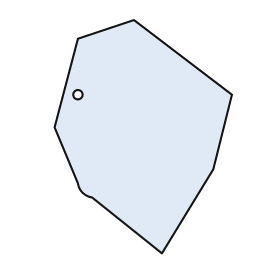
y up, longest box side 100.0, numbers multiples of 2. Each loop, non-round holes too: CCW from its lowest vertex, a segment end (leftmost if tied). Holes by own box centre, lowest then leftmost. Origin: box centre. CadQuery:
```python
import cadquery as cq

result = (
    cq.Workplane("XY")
    .moveTo(8.0, -50.0)
    .lineTo(30.0, -14.0)
    .lineTo(38.0, 18.0)
    .lineTo(-4.0, 50.0)
    .lineTo(-28.0, 42.0)
    .lineTo(-38.0, 4.0)
    .lineTo(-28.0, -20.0)
    .threePointArc((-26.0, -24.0), (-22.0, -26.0))
    .close()
    .moveTo(-28.0, 18.0)
    .circle(2.0)
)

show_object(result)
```